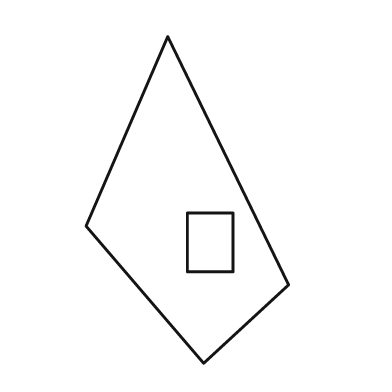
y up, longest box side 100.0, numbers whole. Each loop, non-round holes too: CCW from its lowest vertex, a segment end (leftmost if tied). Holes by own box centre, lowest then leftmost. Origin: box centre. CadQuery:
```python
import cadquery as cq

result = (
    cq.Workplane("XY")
    .moveTo(5.0, -50.0)
    .lineTo(31.0, -26.0)
    .lineTo(-6.0, 50.0)
    .lineTo(-31.0, -8.0)
    .close()
    .moveTo(0.0, -22.0)
    .lineTo(14.0, -22.0)
    .lineTo(14.0, -4.0)
    .lineTo(0.0, -4.0)
    .close()
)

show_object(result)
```